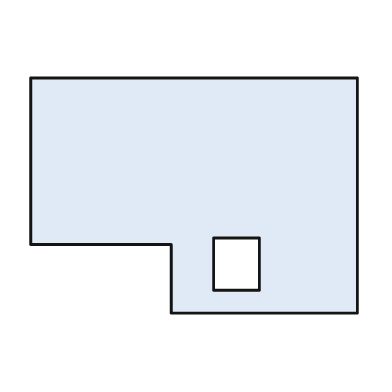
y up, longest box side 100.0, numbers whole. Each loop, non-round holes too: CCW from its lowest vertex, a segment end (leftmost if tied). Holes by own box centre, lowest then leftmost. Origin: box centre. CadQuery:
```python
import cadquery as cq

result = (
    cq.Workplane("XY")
    .moveTo(-7.0, -36.0)
    .lineTo(50.0, -36.0)
    .lineTo(50.0, 36.0)
    .lineTo(-50.0, 36.0)
    .lineTo(-50.0, -15.0)
    .lineTo(-7.0, -15.0)
    .close()
    .moveTo(6.0, -29.0)
    .lineTo(20.0, -29.0)
    .lineTo(20.0, -13.0)
    .lineTo(6.0, -13.0)
    .close()
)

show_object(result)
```